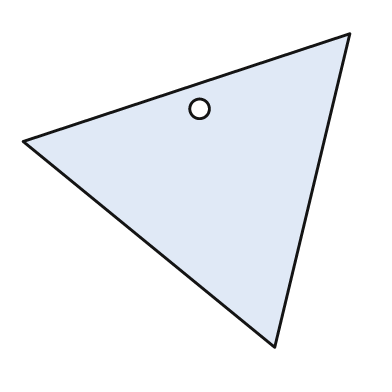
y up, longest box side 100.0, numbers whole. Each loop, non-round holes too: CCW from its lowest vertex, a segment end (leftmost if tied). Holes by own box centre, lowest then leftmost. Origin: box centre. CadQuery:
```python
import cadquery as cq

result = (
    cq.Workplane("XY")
    .moveTo(27.0, -48.0)
    .lineTo(50.0, 48.0)
    .lineTo(-50.0, 15.0)
    .close()
    .moveTo(4.0, 25.0)
    .circle(3.0)
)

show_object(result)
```